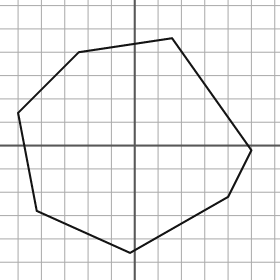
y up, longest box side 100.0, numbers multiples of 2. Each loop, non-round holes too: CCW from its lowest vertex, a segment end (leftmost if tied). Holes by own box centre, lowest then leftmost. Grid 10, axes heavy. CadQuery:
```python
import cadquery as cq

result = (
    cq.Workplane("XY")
    .moveTo(-2.0, -46.0)
    .lineTo(40.0, -22.0)
    .lineTo(50.0, -2.0)
    .lineTo(16.0, 46.0)
    .lineTo(-24.0, 40.0)
    .lineTo(-50.0, 14.0)
    .lineTo(-42.0, -28.0)
    .close()
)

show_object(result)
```